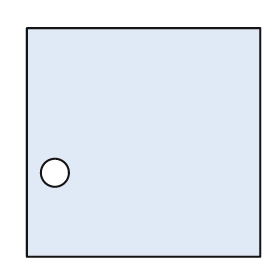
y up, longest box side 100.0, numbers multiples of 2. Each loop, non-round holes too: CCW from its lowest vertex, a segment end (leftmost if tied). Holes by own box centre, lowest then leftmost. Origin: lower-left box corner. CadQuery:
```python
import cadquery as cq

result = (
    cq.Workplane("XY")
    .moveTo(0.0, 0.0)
    .lineTo(100.0, 0.0)
    .lineTo(100.0, 98.0)
    .lineTo(0.0, 98.0)
    .close()
    .moveTo(12.0, 36.0)
    .circle(6.0)
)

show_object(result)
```